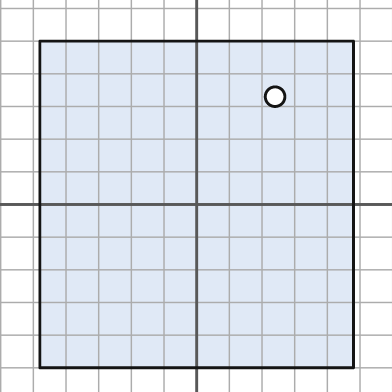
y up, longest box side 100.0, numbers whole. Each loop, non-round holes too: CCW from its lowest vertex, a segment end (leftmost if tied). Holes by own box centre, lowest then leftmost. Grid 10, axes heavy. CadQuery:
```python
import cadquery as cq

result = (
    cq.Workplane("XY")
    .moveTo(-48.0, -50.0)
    .lineTo(48.0, -50.0)
    .lineTo(48.0, 50.0)
    .lineTo(-48.0, 50.0)
    .close()
    .moveTo(24.0, 33.0)
    .circle(3.0)
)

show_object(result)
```